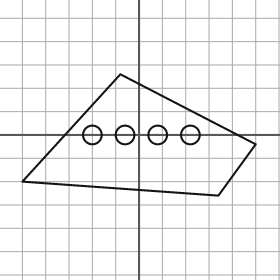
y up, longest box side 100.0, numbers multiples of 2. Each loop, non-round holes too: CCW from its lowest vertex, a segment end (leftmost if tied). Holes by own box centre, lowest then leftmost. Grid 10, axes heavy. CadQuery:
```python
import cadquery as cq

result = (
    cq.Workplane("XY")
    .moveTo(34.0, -26.0)
    .lineTo(50.0, -4.0)
    .lineTo(-8.0, 26.0)
    .lineTo(-50.0, -20.0)
    .close()
    .moveTo(-20.0, 0.0)
    .circle(4.0)
    .moveTo(-6.0, 0.0)
    .circle(4.0)
    .moveTo(8.0, 0.0)
    .circle(4.0)
    .moveTo(22.0, 0.0)
    .circle(4.0)
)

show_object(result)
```